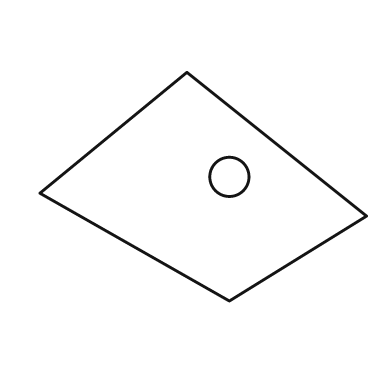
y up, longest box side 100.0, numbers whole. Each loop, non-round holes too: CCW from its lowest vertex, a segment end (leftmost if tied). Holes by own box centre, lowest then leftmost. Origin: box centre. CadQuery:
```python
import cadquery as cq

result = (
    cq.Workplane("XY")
    .moveTo(8.0, -35.0)
    .lineTo(50.0, -9.0)
    .lineTo(-5.0, 35.0)
    .lineTo(-50.0, -2.0)
    .close()
    .moveTo(8.0, 3.0)
    .circle(6.0)
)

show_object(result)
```